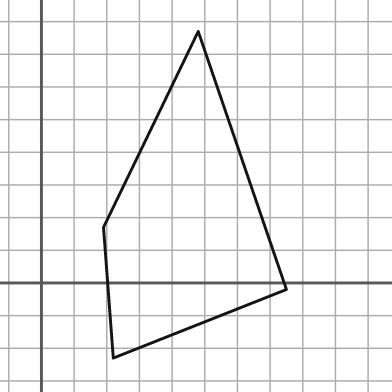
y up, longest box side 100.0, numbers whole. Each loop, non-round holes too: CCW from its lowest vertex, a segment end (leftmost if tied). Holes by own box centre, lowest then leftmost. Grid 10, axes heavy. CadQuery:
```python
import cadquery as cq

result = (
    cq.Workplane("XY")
    .moveTo(22.0, -23.0)
    .lineTo(75.0, -2.0)
    .lineTo(48.0, 77.0)
    .lineTo(19.0, 17.0)
    .close()
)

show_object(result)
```